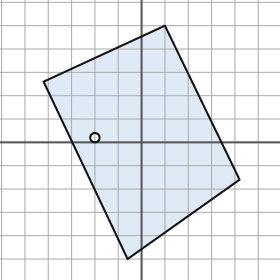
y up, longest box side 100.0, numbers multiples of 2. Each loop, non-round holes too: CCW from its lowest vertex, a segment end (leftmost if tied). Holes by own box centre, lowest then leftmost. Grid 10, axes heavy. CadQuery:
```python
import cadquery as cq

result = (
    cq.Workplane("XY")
    .moveTo(-6.0, -50.0)
    .lineTo(42.0, -16.0)
    .lineTo(10.0, 50.0)
    .lineTo(-42.0, 26.0)
    .close()
    .moveTo(-20.0, 2.0)
    .circle(2.0)
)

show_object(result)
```